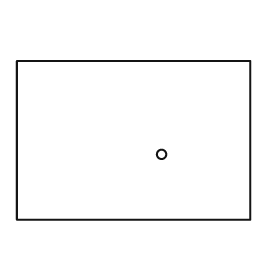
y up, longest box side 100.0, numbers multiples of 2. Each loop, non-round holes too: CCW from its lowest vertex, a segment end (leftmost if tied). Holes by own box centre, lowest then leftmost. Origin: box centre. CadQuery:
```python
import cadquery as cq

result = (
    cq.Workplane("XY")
    .moveTo(-50.0, -34.0)
    .lineTo(50.0, -34.0)
    .lineTo(50.0, 34.0)
    .lineTo(-50.0, 34.0)
    .close()
    .moveTo(12.0, -6.0)
    .circle(2.0)
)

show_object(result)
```